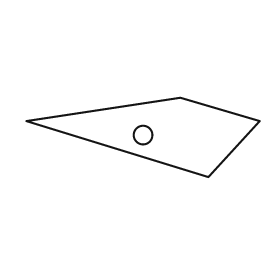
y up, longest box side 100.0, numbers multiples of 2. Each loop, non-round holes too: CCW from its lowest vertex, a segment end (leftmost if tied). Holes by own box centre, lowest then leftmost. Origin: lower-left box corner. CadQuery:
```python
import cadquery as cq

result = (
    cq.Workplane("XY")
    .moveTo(78.0, 0.0)
    .lineTo(100.0, 24.0)
    .lineTo(66.0, 34.0)
    .lineTo(0.0, 24.0)
    .close()
    .moveTo(50.0, 18.0)
    .circle(4.0)
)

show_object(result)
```